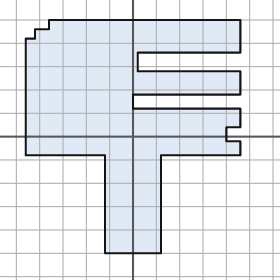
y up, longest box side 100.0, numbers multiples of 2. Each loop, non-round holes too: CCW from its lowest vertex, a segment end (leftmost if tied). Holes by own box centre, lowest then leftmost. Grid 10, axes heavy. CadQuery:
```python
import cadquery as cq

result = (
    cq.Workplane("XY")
    .moveTo(-12.0, -50.0)
    .lineTo(12.0, -50.0)
    .lineTo(12.0, -8.0)
    .lineTo(46.0, -8.0)
    .lineTo(46.0, -2.0)
    .lineTo(40.0, -2.0)
    .lineTo(40.0, 4.0)
    .lineTo(46.0, 4.0)
    .lineTo(46.0, 12.0)
    .lineTo(0.0, 12.0)
    .lineTo(0.0, 18.0)
    .lineTo(46.0, 18.0)
    .lineTo(46.0, 28.0)
    .lineTo(2.0, 28.0)
    .lineTo(2.0, 36.0)
    .lineTo(46.0, 36.0)
    .lineTo(46.0, 50.0)
    .lineTo(-36.0, 50.0)
    .lineTo(-36.0, 46.0)
    .lineTo(-42.0, 46.0)
    .lineTo(-42.0, 42.0)
    .lineTo(-46.0, 42.0)
    .lineTo(-46.0, -8.0)
    .lineTo(-12.0, -8.0)
    .close()
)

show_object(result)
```